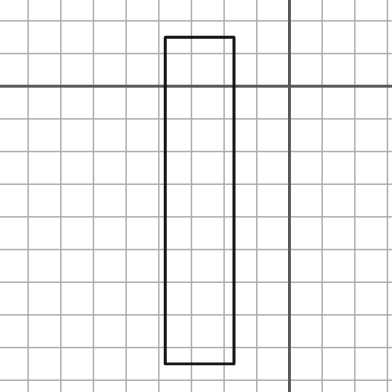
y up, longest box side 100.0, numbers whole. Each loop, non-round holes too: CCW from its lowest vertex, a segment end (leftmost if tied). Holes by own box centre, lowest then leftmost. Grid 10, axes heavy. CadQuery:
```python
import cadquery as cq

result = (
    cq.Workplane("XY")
    .moveTo(-38.0, -85.0)
    .lineTo(-17.0, -85.0)
    .lineTo(-17.0, 15.0)
    .lineTo(-38.0, 15.0)
    .close()
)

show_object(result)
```